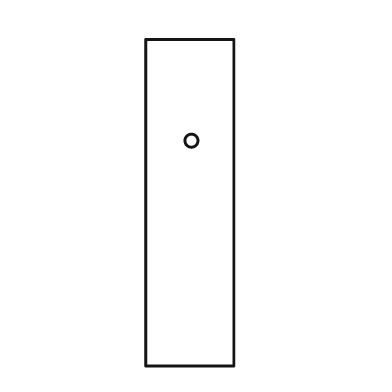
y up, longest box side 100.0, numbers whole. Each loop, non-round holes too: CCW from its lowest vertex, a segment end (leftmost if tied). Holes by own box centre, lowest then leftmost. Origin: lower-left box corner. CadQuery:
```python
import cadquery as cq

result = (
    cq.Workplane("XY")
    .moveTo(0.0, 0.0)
    .lineTo(27.0, 0.0)
    .lineTo(27.0, 100.0)
    .lineTo(0.0, 100.0)
    .close()
    .moveTo(14.0, 69.0)
    .circle(2.0)
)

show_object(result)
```